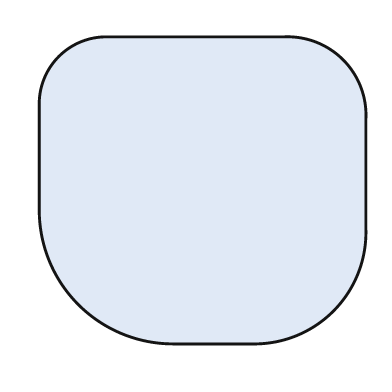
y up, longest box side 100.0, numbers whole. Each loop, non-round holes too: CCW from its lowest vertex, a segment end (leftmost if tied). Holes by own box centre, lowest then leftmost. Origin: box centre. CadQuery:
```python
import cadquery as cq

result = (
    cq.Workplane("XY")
    .moveTo(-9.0, -47.0)
    .lineTo(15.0, -47.0)
    .threePointArc((40.0, -37.0), (50.0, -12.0))
    .lineTo(50.0, 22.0)
    .threePointArc((43.0, 40.0), (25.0, 47.0))
    .lineTo(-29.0, 47.0)
    .threePointArc((-44.0, 41.0), (-50.0, 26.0))
    .lineTo(-50.0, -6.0)
    .threePointArc((-38.0, -35.0), (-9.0, -47.0))
    .close()
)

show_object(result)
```